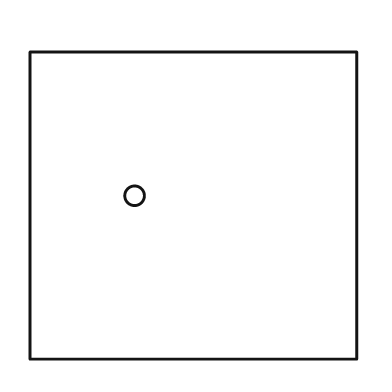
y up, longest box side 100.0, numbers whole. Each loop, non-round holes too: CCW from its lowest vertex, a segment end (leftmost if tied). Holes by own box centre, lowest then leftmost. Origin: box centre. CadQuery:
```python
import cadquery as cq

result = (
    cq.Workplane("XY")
    .moveTo(-50.0, -47.0)
    .lineTo(50.0, -47.0)
    .lineTo(50.0, 47.0)
    .lineTo(-50.0, 47.0)
    .close()
    .moveTo(-18.0, 3.0)
    .circle(3.0)
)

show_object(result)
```